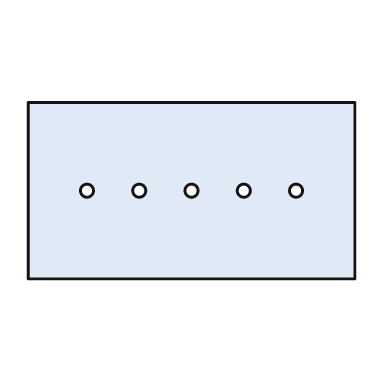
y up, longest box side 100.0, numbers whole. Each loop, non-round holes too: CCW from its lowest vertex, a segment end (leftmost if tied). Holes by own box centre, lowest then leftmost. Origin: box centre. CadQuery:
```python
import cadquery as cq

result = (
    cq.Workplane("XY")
    .moveTo(-50.0, -27.0)
    .lineTo(50.0, -27.0)
    .lineTo(50.0, 27.0)
    .lineTo(-50.0, 27.0)
    .close()
    .moveTo(-32.0, 0.0)
    .circle(2.0)
    .moveTo(-16.0, 0.0)
    .circle(2.0)
    .moveTo(0.0, 0.0)
    .circle(2.0)
    .moveTo(16.0, 0.0)
    .circle(2.0)
    .moveTo(32.0, 0.0)
    .circle(2.0)
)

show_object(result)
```